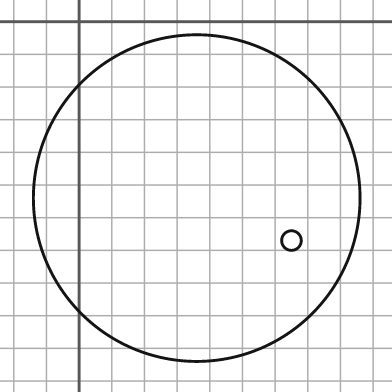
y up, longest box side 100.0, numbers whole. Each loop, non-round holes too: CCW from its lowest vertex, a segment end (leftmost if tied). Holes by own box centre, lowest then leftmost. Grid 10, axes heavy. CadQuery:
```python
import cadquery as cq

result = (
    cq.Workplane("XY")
    .moveTo(36.0, -54.0)
    .circle(50.0)
    .moveTo(65.0, -67.0)
    .circle(3.0)
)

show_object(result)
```